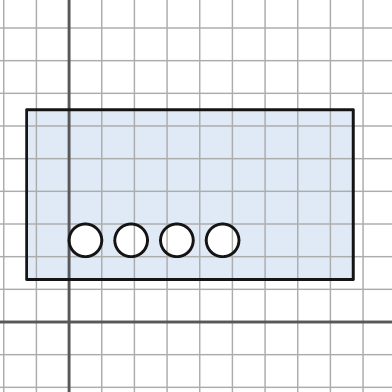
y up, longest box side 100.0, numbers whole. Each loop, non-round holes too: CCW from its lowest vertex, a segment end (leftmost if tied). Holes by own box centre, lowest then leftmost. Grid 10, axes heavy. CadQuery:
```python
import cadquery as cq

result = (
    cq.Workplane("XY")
    .moveTo(-13.0, 13.0)
    .lineTo(87.0, 13.0)
    .lineTo(87.0, 65.0)
    .lineTo(-13.0, 65.0)
    .close()
    .moveTo(5.0, 25.0)
    .circle(5.0)
    .moveTo(19.0, 25.0)
    .circle(5.0)
    .moveTo(33.0, 25.0)
    .circle(5.0)
    .moveTo(47.0, 25.0)
    .circle(5.0)
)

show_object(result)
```